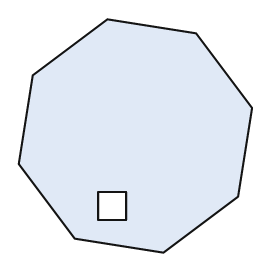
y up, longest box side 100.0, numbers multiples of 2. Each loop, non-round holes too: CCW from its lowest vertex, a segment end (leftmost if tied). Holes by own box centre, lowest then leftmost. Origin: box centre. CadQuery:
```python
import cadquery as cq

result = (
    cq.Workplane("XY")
    .moveTo(12.0, -50.0)
    .lineTo(44.0, -26.0)
    .lineTo(50.0, 12.0)
    .lineTo(26.0, 44.0)
    .lineTo(-12.0, 50.0)
    .lineTo(-44.0, 26.0)
    .lineTo(-50.0, -12.0)
    .lineTo(-26.0, -44.0)
    .close()
    .moveTo(-16.0, -36.0)
    .lineTo(-4.0, -36.0)
    .lineTo(-4.0, -24.0)
    .lineTo(-16.0, -24.0)
    .close()
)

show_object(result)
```